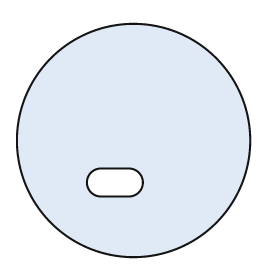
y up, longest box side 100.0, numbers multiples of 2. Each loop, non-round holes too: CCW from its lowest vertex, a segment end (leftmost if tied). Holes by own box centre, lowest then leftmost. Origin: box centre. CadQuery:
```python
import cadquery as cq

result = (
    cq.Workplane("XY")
    .moveTo(0.0, 0.0)
    .circle(50.0)
    .moveTo(-14.0, -24.0)
    .lineTo(-2.0, -24.0)
    .threePointArc((4.0, -18.0), (-2.0, -12.0))
    .lineTo(-14.0, -12.0)
    .threePointArc((-20.0, -18.0), (-14.0, -24.0))
    .close()
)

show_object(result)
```